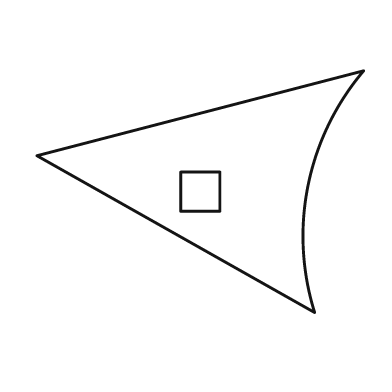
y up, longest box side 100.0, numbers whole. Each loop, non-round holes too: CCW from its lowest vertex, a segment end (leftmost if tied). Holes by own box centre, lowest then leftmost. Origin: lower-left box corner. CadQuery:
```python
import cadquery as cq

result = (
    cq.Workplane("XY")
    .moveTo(85.0, 0.0)
    .threePointArc((83.0, 39.0), (100.0, 74.0))
    .lineTo(0.0, 48.0)
    .close()
    .moveTo(44.0, 31.0)
    .lineTo(56.0, 31.0)
    .lineTo(56.0, 43.0)
    .lineTo(44.0, 43.0)
    .close()
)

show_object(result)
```